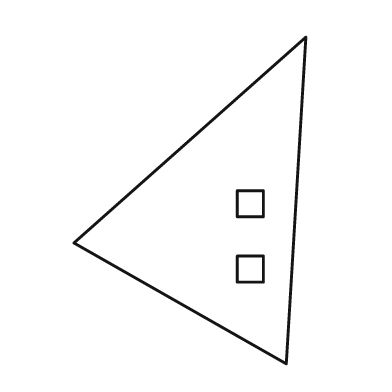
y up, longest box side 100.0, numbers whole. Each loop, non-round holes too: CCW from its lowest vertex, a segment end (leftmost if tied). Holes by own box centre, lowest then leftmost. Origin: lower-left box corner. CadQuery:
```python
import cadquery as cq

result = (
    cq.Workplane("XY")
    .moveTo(65.0, 0.0)
    .lineTo(71.0, 100.0)
    .lineTo(0.0, 37.0)
    .close()
    .moveTo(50.0, 25.0)
    .lineTo(58.0, 25.0)
    .lineTo(58.0, 33.0)
    .lineTo(50.0, 33.0)
    .close()
    .moveTo(50.0, 45.0)
    .lineTo(58.0, 45.0)
    .lineTo(58.0, 53.0)
    .lineTo(50.0, 53.0)
    .close()
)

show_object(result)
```